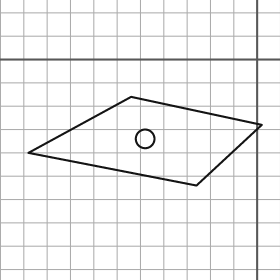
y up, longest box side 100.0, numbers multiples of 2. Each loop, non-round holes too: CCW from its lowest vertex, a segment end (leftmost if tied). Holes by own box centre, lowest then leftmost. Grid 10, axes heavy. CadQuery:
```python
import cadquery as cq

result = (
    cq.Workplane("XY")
    .moveTo(-26.0, -54.0)
    .lineTo(2.0, -28.0)
    .lineTo(-54.0, -16.0)
    .lineTo(-98.0, -40.0)
    .close()
    .moveTo(-48.0, -34.0)
    .circle(4.0)
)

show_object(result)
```